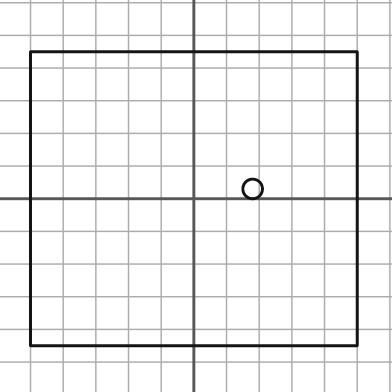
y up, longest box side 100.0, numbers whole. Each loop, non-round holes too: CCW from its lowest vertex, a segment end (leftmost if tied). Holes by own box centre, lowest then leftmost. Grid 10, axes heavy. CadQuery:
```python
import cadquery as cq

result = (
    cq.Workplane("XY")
    .moveTo(-50.0, -45.0)
    .lineTo(50.0, -45.0)
    .lineTo(50.0, 45.0)
    .lineTo(-50.0, 45.0)
    .close()
    .moveTo(18.0, 3.0)
    .circle(3.0)
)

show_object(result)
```